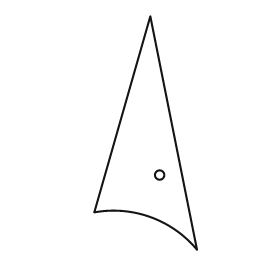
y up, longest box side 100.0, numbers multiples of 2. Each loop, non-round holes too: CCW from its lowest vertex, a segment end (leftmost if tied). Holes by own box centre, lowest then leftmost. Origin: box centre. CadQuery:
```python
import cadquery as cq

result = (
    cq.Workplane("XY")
    .moveTo(22.0, -50.0)
    .lineTo(2.0, 50.0)
    .lineTo(-22.0, -34.0)
    .threePointArc((2.0, -36.0), (22.0, -50.0))
    .close()
    .moveTo(6.0, -18.0)
    .circle(2.0)
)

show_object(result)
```